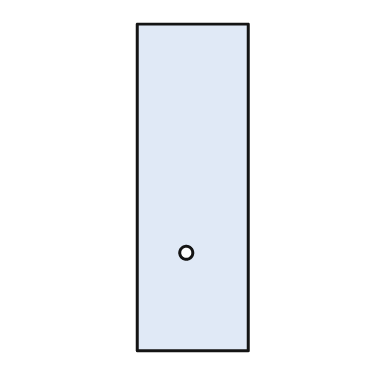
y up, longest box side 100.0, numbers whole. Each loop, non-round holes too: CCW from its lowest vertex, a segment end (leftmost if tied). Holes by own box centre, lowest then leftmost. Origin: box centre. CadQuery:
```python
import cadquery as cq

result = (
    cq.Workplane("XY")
    .moveTo(-17.0, -50.0)
    .lineTo(17.0, -50.0)
    .lineTo(17.0, 50.0)
    .lineTo(-17.0, 50.0)
    .close()
    .moveTo(-2.0, -20.0)
    .circle(2.0)
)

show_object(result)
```